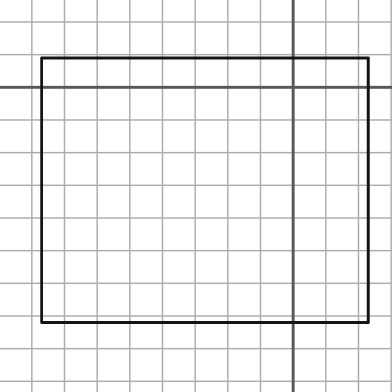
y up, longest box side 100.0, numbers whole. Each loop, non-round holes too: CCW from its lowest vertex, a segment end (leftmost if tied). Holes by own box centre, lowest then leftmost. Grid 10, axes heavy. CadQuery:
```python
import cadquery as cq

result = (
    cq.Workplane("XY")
    .moveTo(-77.0, -72.0)
    .lineTo(23.0, -72.0)
    .lineTo(23.0, 9.0)
    .lineTo(-77.0, 9.0)
    .close()
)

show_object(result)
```